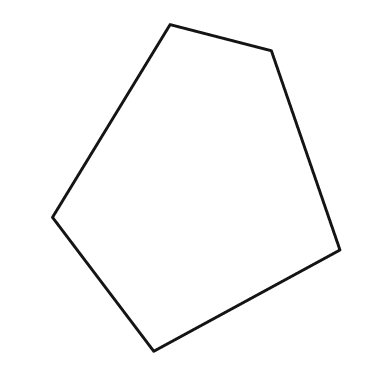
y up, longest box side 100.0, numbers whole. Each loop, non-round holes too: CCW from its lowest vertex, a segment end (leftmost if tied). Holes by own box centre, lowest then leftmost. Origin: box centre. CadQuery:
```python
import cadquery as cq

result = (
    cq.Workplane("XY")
    .moveTo(-13.0, -50.0)
    .lineTo(44.0, -19.0)
    .lineTo(23.0, 42.0)
    .lineTo(-8.0, 50.0)
    .lineTo(-44.0, -9.0)
    .close()
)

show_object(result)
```